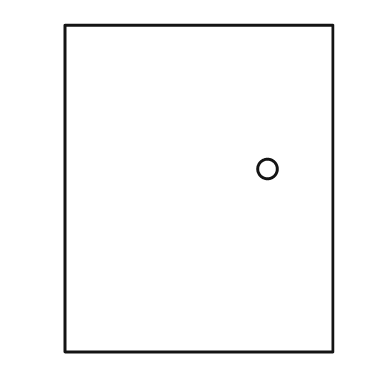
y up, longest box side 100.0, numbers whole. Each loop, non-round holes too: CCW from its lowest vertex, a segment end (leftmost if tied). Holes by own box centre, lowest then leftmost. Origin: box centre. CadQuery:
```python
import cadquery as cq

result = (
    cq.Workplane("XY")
    .moveTo(-41.0, -50.0)
    .lineTo(41.0, -50.0)
    .lineTo(41.0, 50.0)
    .lineTo(-41.0, 50.0)
    .close()
    .moveTo(21.0, 6.0)
    .circle(3.0)
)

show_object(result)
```